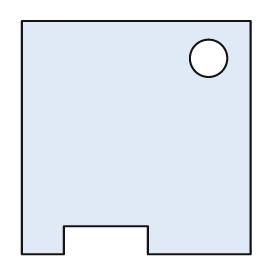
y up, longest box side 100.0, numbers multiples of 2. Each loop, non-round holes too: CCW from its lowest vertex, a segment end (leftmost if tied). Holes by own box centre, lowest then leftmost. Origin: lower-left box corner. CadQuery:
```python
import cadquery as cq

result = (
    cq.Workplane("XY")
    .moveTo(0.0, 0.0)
    .lineTo(18.0, 0.0)
    .lineTo(18.0, 12.0)
    .lineTo(54.0, 12.0)
    .lineTo(54.0, 0.0)
    .lineTo(98.0, 0.0)
    .lineTo(98.0, 100.0)
    .lineTo(0.0, 100.0)
    .close()
    .moveTo(80.0, 84.0)
    .circle(8.0)
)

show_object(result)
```